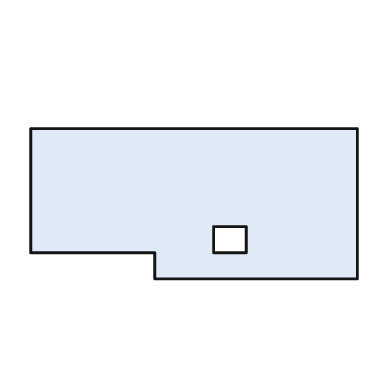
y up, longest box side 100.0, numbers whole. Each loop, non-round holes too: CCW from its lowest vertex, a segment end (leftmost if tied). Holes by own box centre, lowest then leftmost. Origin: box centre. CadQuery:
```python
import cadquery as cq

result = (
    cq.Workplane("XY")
    .moveTo(-12.0, -23.0)
    .lineTo(50.0, -23.0)
    .lineTo(50.0, 23.0)
    .lineTo(-50.0, 23.0)
    .lineTo(-50.0, -15.0)
    .lineTo(-12.0, -15.0)
    .close()
    .moveTo(6.0, -15.0)
    .lineTo(16.0, -15.0)
    .lineTo(16.0, -7.0)
    .lineTo(6.0, -7.0)
    .close()
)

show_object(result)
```